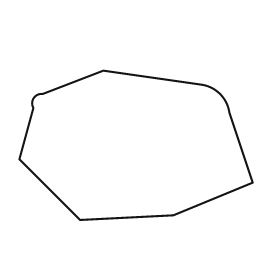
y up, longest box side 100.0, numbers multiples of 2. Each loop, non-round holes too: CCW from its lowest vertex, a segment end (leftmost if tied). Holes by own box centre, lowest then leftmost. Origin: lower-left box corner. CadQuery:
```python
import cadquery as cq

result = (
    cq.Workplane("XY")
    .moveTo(26.0, 0.0)
    .lineTo(66.0, 2.0)
    .lineTo(100.0, 16.0)
    .lineTo(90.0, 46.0)
    .threePointArc((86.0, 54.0), (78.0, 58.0))
    .lineTo(36.0, 64.0)
    .lineTo(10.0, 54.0)
    .threePointArc((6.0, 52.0), (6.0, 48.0))
    .lineTo(0.0, 26.0)
    .close()
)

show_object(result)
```